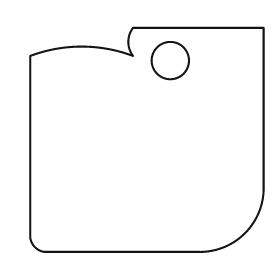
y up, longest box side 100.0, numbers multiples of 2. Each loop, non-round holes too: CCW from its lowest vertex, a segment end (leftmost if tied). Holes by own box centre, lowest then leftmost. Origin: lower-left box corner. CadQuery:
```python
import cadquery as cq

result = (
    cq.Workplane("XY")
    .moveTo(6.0, 0.0)
    .lineTo(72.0, 0.0)
    .threePointArc((92.0, 8.0), (100.0, 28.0))
    .lineTo(100.0, 96.0)
    .lineTo(44.0, 96.0)
    .threePointArc((42.0, 90.0), (44.0, 84.0))
    .threePointArc((22.0, 88.0), (0.0, 84.0))
    .lineTo(0.0, 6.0)
    .threePointArc((2.0, 2.0), (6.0, 0.0))
    .close()
    .moveTo(60.0, 82.0)
    .circle(8.0)
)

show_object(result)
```